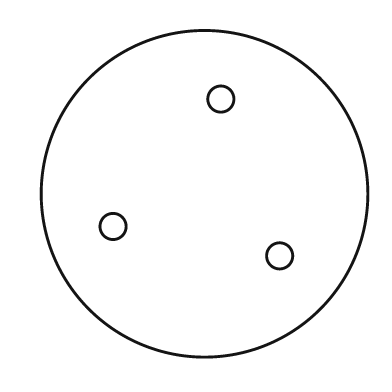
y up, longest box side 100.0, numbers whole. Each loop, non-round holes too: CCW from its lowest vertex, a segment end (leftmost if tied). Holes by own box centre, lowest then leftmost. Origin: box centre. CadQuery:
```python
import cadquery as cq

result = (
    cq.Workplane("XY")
    .moveTo(0.0, 0.0)
    .circle(50.0)
    .moveTo(23.0, -19.0)
    .circle(4.0)
    .moveTo(-28.0, -10.0)
    .circle(4.0)
    .moveTo(5.0, 29.0)
    .circle(4.0)
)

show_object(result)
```